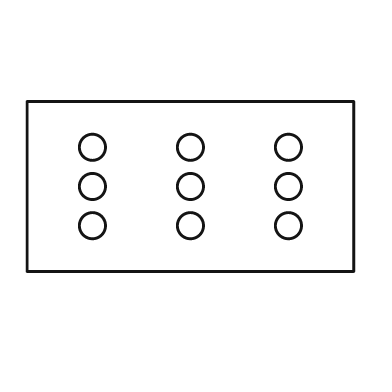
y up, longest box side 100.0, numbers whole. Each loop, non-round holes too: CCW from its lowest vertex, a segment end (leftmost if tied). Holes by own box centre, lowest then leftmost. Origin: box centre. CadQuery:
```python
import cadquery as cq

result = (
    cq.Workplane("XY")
    .moveTo(-50.0, -26.0)
    .lineTo(50.0, -26.0)
    .lineTo(50.0, 26.0)
    .lineTo(-50.0, 26.0)
    .close()
    .moveTo(-30.0, -12.0)
    .circle(4.0)
    .moveTo(0.0, -12.0)
    .circle(4.0)
    .moveTo(30.0, -12.0)
    .circle(4.0)
    .moveTo(-30.0, 0.0)
    .circle(4.0)
    .moveTo(0.0, 0.0)
    .circle(4.0)
    .moveTo(30.0, 0.0)
    .circle(4.0)
    .moveTo(-30.0, 12.0)
    .circle(4.0)
    .moveTo(0.0, 12.0)
    .circle(4.0)
    .moveTo(30.0, 12.0)
    .circle(4.0)
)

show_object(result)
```